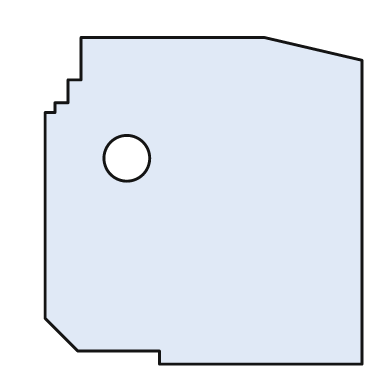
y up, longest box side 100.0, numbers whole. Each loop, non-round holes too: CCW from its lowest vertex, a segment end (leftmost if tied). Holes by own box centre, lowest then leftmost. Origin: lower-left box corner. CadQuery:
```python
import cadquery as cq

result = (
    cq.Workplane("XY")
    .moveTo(35.0, 0.0)
    .lineTo(97.0, 0.0)
    .lineTo(97.0, 93.0)
    .lineTo(67.0, 100.0)
    .lineTo(11.0, 100.0)
    .lineTo(11.0, 87.0)
    .lineTo(7.0, 87.0)
    .lineTo(7.0, 80.0)
    .lineTo(3.0, 80.0)
    .lineTo(3.0, 77.0)
    .lineTo(0.0, 77.0)
    .lineTo(0.0, 14.0)
    .lineTo(10.0, 4.0)
    .lineTo(35.0, 4.0)
    .close()
    .moveTo(25.0, 63.0)
    .circle(7.0)
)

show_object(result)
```